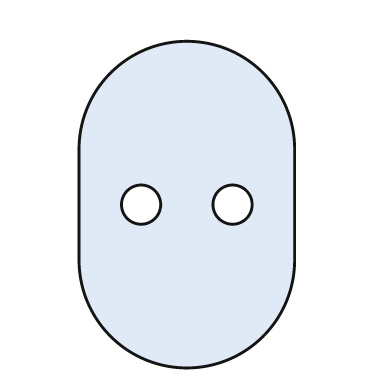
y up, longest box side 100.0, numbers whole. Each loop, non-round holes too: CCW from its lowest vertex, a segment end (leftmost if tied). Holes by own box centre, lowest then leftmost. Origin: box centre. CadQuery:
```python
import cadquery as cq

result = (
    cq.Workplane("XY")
    .moveTo(-33.0, -17.0)
    .threePointArc((0.0, -50.0), (33.0, -17.0))
    .lineTo(33.0, 17.0)
    .threePointArc((0.0, 50.0), (-33.0, 17.0))
    .close()
    .moveTo(-14.0, 0.0)
    .circle(6.0)
    .moveTo(14.0, 0.0)
    .circle(6.0)
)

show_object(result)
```